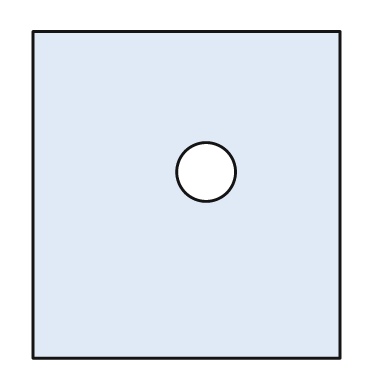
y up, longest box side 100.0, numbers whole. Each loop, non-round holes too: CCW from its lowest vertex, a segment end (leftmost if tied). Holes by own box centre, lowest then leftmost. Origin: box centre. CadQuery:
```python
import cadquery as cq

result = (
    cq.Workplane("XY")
    .moveTo(-47.0, -50.0)
    .lineTo(47.0, -50.0)
    .lineTo(47.0, 50.0)
    .lineTo(-47.0, 50.0)
    .close()
    .moveTo(6.0, 7.0)
    .circle(9.0)
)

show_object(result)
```